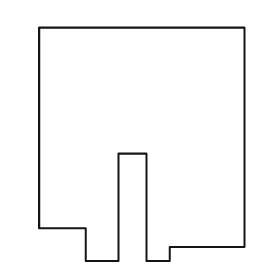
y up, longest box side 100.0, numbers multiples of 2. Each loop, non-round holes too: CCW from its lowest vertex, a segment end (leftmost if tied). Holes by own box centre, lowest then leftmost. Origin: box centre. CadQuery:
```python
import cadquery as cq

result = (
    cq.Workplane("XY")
    .moveTo(-24.0, -50.0)
    .lineTo(-10.0, -50.0)
    .lineTo(-10.0, -4.0)
    .lineTo(2.0, -4.0)
    .lineTo(2.0, -50.0)
    .lineTo(12.0, -50.0)
    .lineTo(12.0, -44.0)
    .lineTo(44.0, -44.0)
    .lineTo(44.0, 50.0)
    .lineTo(-44.0, 50.0)
    .lineTo(-44.0, -36.0)
    .lineTo(-24.0, -36.0)
    .close()
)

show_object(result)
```